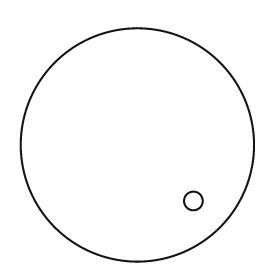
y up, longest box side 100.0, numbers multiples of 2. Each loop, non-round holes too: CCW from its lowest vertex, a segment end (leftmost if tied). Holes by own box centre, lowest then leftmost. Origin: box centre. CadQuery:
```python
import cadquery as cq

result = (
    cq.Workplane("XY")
    .moveTo(0.0, 0.0)
    .circle(50.0)
    .moveTo(24.0, -24.0)
    .circle(4.0)
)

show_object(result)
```